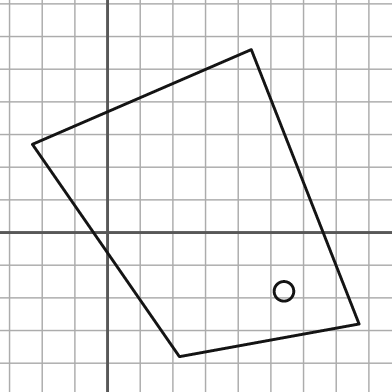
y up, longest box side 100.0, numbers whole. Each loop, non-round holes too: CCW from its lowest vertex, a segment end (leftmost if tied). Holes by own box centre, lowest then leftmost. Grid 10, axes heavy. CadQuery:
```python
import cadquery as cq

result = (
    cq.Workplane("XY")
    .moveTo(22.0, -38.0)
    .lineTo(77.0, -28.0)
    .lineTo(44.0, 56.0)
    .lineTo(-23.0, 27.0)
    .close()
    .moveTo(54.0, -18.0)
    .circle(3.0)
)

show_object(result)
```